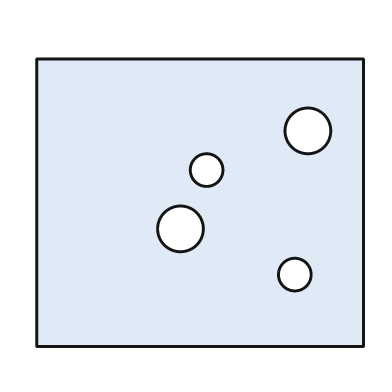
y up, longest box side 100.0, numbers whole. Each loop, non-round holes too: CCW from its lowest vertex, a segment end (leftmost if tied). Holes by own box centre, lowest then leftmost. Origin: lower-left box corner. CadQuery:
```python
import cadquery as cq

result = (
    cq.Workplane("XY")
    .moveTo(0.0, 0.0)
    .lineTo(100.0, 0.0)
    .lineTo(100.0, 88.0)
    .lineTo(0.0, 88.0)
    .close()
    .moveTo(79.0, 22.0)
    .circle(5.0)
    .moveTo(44.0, 36.0)
    .circle(7.0)
    .moveTo(52.0, 54.0)
    .circle(5.0)
    .moveTo(83.0, 66.0)
    .circle(7.0)
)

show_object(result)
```